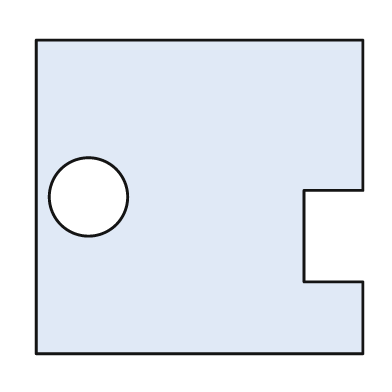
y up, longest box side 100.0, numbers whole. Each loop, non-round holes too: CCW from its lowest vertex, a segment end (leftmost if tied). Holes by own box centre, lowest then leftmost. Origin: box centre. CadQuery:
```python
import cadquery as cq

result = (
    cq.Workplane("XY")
    .moveTo(-50.0, -48.0)
    .lineTo(50.0, -48.0)
    .lineTo(50.0, -26.0)
    .lineTo(32.0, -26.0)
    .lineTo(32.0, 2.0)
    .lineTo(50.0, 2.0)
    .lineTo(50.0, 48.0)
    .lineTo(-50.0, 48.0)
    .close()
    .moveTo(-34.0, 0.0)
    .circle(12.0)
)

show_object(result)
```